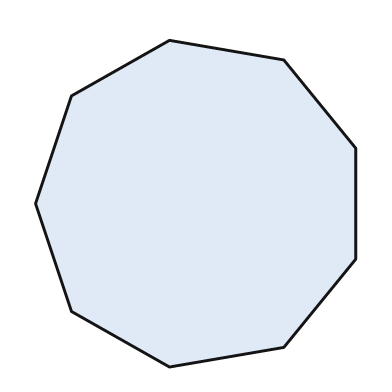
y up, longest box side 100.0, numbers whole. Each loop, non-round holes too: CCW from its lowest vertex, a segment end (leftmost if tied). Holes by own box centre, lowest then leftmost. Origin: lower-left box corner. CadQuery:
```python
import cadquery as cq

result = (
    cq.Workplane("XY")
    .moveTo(41.0, 0.0)
    .lineTo(76.0, 6.0)
    .lineTo(98.0, 33.0)
    .lineTo(98.0, 67.0)
    .lineTo(76.0, 94.0)
    .lineTo(41.0, 100.0)
    .lineTo(11.0, 83.0)
    .lineTo(0.0, 50.0)
    .lineTo(11.0, 17.0)
    .close()
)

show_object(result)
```